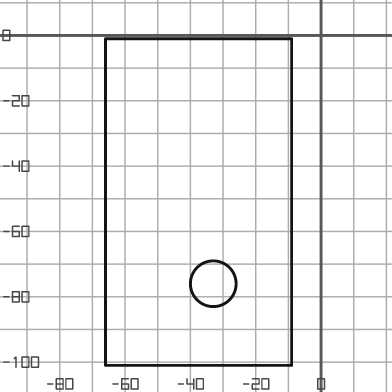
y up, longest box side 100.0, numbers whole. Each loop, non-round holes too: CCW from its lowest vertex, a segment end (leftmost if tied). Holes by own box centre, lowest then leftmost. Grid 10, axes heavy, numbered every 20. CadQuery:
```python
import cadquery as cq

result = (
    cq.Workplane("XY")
    .moveTo(-66.0, -101.0)
    .lineTo(-9.0, -101.0)
    .lineTo(-9.0, -1.0)
    .lineTo(-66.0, -1.0)
    .close()
    .moveTo(-33.0, -76.0)
    .circle(7.0)
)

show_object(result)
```